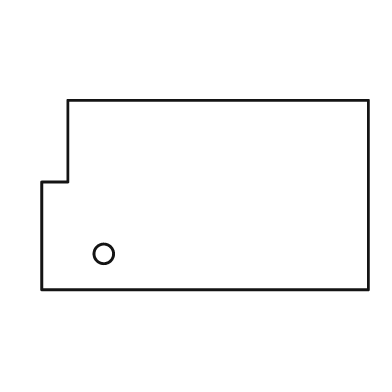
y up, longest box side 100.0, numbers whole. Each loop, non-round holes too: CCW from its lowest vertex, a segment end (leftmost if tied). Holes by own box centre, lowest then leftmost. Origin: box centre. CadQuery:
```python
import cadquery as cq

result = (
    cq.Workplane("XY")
    .moveTo(-50.0, -29.0)
    .lineTo(50.0, -29.0)
    .lineTo(50.0, 29.0)
    .lineTo(-42.0, 29.0)
    .lineTo(-42.0, 4.0)
    .lineTo(-50.0, 4.0)
    .close()
    .moveTo(-31.0, -18.0)
    .circle(3.0)
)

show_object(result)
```